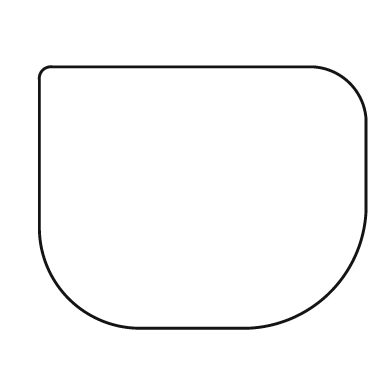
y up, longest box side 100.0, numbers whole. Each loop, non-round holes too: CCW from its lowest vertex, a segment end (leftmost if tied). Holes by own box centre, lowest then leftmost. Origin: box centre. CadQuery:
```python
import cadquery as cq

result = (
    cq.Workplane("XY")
    .moveTo(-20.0, -40.0)
    .lineTo(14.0, -40.0)
    .threePointArc((39.0, -29.0), (50.0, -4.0))
    .lineTo(50.0, 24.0)
    .threePointArc((45.0, 35.0), (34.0, 40.0))
    .lineTo(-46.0, 40.0)
    .threePointArc((-49.0, 39.0), (-50.0, 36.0))
    .lineTo(-50.0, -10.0)
    .threePointArc((-41.0, -31.0), (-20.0, -40.0))
    .close()
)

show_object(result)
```